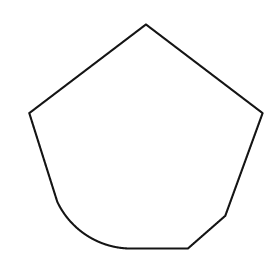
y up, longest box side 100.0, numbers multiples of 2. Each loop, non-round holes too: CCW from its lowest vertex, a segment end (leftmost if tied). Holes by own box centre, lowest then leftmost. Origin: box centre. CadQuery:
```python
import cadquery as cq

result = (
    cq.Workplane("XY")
    .moveTo(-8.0, -48.0)
    .lineTo(18.0, -48.0)
    .lineTo(34.0, -34.0)
    .lineTo(50.0, 10.0)
    .lineTo(0.0, 48.0)
    .lineTo(-50.0, 10.0)
    .lineTo(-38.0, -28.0)
    .threePointArc((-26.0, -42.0), (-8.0, -48.0))
    .close()
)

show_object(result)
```